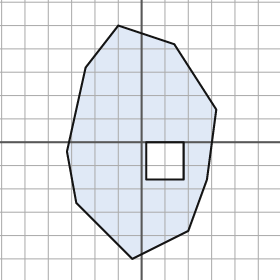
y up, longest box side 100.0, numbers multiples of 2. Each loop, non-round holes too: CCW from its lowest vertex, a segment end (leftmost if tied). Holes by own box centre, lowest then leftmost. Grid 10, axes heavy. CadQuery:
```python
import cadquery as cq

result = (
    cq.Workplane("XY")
    .moveTo(-4.0, -50.0)
    .lineTo(20.0, -38.0)
    .lineTo(28.0, -16.0)
    .lineTo(32.0, 14.0)
    .lineTo(14.0, 42.0)
    .lineTo(-10.0, 50.0)
    .lineTo(-24.0, 32.0)
    .lineTo(-32.0, -4.0)
    .lineTo(-28.0, -26.0)
    .close()
    .moveTo(2.0, -16.0)
    .lineTo(18.0, -16.0)
    .lineTo(18.0, 0.0)
    .lineTo(2.0, 0.0)
    .close()
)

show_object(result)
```